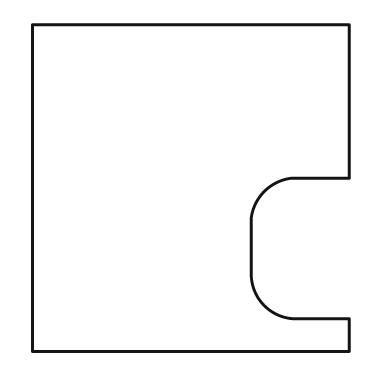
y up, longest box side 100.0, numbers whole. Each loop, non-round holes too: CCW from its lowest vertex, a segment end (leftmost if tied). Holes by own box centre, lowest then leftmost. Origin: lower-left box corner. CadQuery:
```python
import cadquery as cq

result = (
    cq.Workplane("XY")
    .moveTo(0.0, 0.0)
    .lineTo(97.0, 0.0)
    .lineTo(97.0, 10.0)
    .lineTo(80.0, 10.0)
    .threePointArc((71.0, 14.0), (67.0, 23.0))
    .lineTo(67.0, 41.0)
    .threePointArc((71.0, 49.0), (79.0, 53.0))
    .lineTo(97.0, 53.0)
    .lineTo(97.0, 100.0)
    .lineTo(0.0, 100.0)
    .close()
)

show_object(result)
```